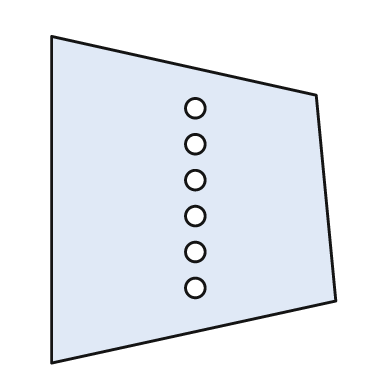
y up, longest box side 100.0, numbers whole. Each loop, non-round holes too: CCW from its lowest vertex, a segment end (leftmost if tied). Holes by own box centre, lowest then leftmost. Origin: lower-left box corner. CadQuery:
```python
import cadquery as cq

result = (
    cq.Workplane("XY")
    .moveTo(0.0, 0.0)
    .lineTo(87.0, 19.0)
    .lineTo(81.0, 82.0)
    .lineTo(0.0, 100.0)
    .close()
    .moveTo(44.0, 23.0)
    .circle(3.0)
    .moveTo(44.0, 34.0)
    .circle(3.0)
    .moveTo(44.0, 45.0)
    .circle(3.0)
    .moveTo(44.0, 56.0)
    .circle(3.0)
    .moveTo(44.0, 67.0)
    .circle(3.0)
    .moveTo(44.0, 78.0)
    .circle(3.0)
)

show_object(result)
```